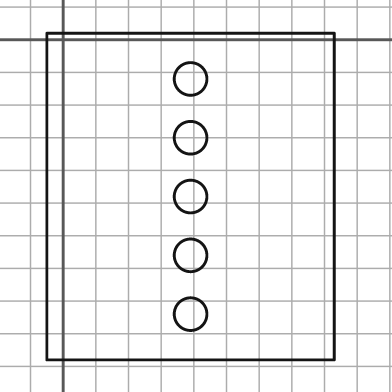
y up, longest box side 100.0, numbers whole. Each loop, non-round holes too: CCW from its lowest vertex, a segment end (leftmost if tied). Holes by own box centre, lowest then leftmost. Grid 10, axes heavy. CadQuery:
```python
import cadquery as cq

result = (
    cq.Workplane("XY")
    .moveTo(-5.0, -98.0)
    .lineTo(83.0, -98.0)
    .lineTo(83.0, 2.0)
    .lineTo(-5.0, 2.0)
    .close()
    .moveTo(39.0, -84.0)
    .circle(5.0)
    .moveTo(39.0, -66.0)
    .circle(5.0)
    .moveTo(39.0, -48.0)
    .circle(5.0)
    .moveTo(39.0, -30.0)
    .circle(5.0)
    .moveTo(39.0, -12.0)
    .circle(5.0)
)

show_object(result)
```